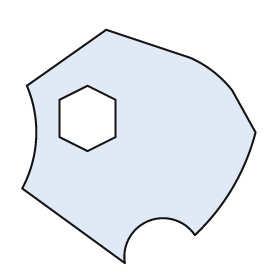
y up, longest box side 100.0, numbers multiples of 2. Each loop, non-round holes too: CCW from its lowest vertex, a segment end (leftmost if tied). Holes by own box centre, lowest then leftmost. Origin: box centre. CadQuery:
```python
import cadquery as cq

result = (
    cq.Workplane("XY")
    .moveTo(-6.0, -50.0)
    .threePointArc((4.0, -32.0), (24.0, -38.0))
    .threePointArc((40.0, -18.0), (50.0, 6.0))
    .lineTo(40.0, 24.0)
    .threePointArc((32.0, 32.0), (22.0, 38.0))
    .lineTo(-14.0, 50.0)
    .lineTo(-48.0, 26.0)
    .threePointArc((-44.0, 4.0), (-50.0, -18.0))
    .close()
    .moveTo(-22.0, -2.0)
    .lineTo(-10.0, 4.0)
    .lineTo(-10.0, 20.0)
    .lineTo(-22.0, 26.0)
    .lineTo(-34.0, 20.0)
    .lineTo(-34.0, 4.0)
    .close()
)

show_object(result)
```